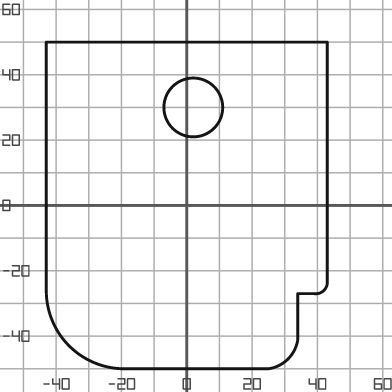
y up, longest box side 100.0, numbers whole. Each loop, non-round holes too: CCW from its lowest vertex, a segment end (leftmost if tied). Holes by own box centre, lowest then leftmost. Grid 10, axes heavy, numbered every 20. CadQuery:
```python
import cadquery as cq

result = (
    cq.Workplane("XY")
    .moveTo(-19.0, -50.0)
    .lineTo(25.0, -50.0)
    .threePointArc((31.0, -47.0), (34.0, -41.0))
    .lineTo(34.0, -27.0)
    .lineTo(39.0, -27.0)
    .threePointArc((42.0, -26.0), (43.0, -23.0))
    .lineTo(43.0, 50.0)
    .lineTo(-43.0, 50.0)
    .lineTo(-43.0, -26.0)
    .threePointArc((-36.0, -43.0), (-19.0, -50.0))
    .close()
    .moveTo(2.0, 30.0)
    .circle(9.0)
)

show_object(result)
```